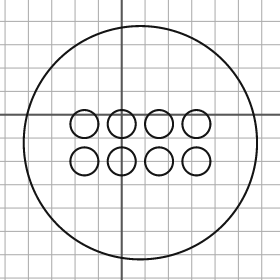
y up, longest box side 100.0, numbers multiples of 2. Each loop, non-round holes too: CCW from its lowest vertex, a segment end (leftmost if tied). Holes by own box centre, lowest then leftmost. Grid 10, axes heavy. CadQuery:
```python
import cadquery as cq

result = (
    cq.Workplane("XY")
    .moveTo(8.0, -12.0)
    .circle(50.0)
    .moveTo(-16.0, -20.0)
    .circle(6.0)
    .moveTo(0.0, -20.0)
    .circle(6.0)
    .moveTo(16.0, -20.0)
    .circle(6.0)
    .moveTo(32.0, -20.0)
    .circle(6.0)
    .moveTo(-16.0, -4.0)
    .circle(6.0)
    .moveTo(0.0, -4.0)
    .circle(6.0)
    .moveTo(16.0, -4.0)
    .circle(6.0)
    .moveTo(32.0, -4.0)
    .circle(6.0)
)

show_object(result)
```